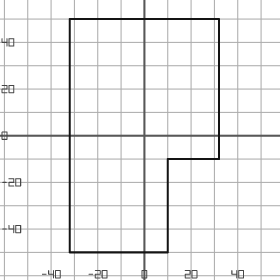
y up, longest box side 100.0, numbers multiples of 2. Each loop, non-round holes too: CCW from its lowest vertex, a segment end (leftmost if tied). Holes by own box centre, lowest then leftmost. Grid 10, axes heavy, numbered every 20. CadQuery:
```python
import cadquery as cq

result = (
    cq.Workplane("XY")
    .moveTo(-32.0, -50.0)
    .lineTo(10.0, -50.0)
    .lineTo(10.0, -10.0)
    .lineTo(32.0, -10.0)
    .lineTo(32.0, 50.0)
    .lineTo(-32.0, 50.0)
    .close()
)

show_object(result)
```